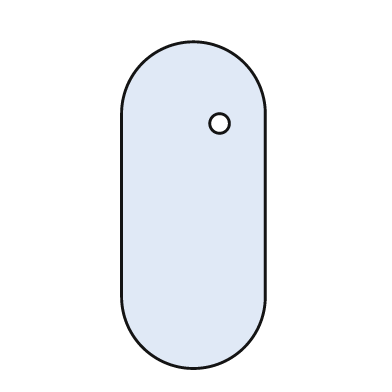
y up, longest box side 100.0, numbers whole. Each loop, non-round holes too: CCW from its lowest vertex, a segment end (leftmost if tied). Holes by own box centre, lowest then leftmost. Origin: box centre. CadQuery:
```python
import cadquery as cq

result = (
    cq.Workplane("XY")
    .moveTo(-22.0, -28.0)
    .threePointArc((0.0, -50.0), (22.0, -28.0))
    .lineTo(22.0, 28.0)
    .threePointArc((0.0, 50.0), (-22.0, 28.0))
    .close()
    .moveTo(8.0, 25.0)
    .circle(3.0)
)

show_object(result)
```